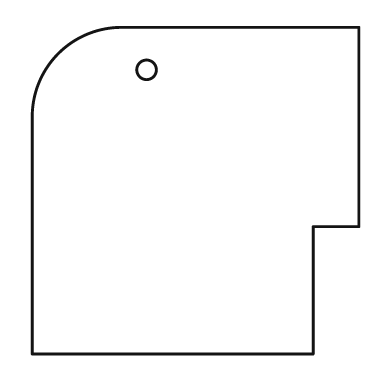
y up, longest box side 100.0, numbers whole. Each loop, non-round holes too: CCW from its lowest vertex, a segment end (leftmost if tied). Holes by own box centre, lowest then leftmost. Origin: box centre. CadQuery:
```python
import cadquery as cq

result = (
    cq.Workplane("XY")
    .moveTo(-50.0, -50.0)
    .lineTo(36.0, -50.0)
    .lineTo(36.0, -11.0)
    .lineTo(50.0, -11.0)
    .lineTo(50.0, 50.0)
    .lineTo(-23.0, 50.0)
    .threePointArc((-42.0, 42.0), (-50.0, 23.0))
    .close()
    .moveTo(-15.0, 37.0)
    .circle(3.0)
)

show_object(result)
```